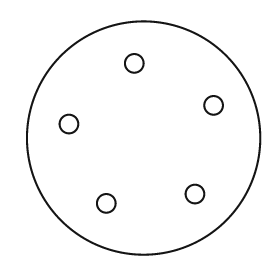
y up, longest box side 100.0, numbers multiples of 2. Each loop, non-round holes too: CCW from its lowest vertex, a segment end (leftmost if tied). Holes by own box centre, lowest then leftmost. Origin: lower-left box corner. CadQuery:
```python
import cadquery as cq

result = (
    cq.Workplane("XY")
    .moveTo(50.0, 50.0)
    .circle(50.0)
    .moveTo(34.0, 22.0)
    .circle(4.0)
    .moveTo(72.0, 26.0)
    .circle(4.0)
    .moveTo(18.0, 56.0)
    .circle(4.0)
    .moveTo(80.0, 64.0)
    .circle(4.0)
    .moveTo(46.0, 82.0)
    .circle(4.0)
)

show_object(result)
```